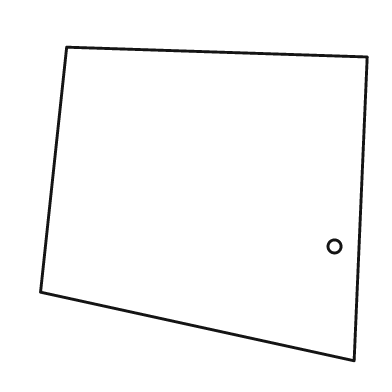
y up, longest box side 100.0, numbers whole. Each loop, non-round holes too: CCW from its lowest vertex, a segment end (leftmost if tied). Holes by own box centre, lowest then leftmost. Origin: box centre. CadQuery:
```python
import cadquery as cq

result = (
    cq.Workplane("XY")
    .moveTo(46.0, -48.0)
    .lineTo(50.0, 45.0)
    .lineTo(-42.0, 48.0)
    .lineTo(-50.0, -27.0)
    .close()
    .moveTo(40.0, -13.0)
    .circle(2.0)
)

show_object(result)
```